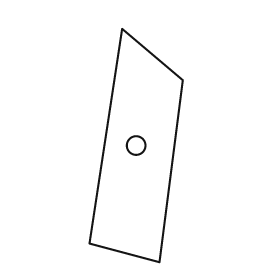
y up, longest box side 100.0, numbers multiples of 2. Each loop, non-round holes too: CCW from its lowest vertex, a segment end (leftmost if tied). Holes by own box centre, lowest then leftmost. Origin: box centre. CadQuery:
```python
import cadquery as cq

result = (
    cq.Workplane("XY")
    .moveTo(10.0, -50.0)
    .lineTo(20.0, 28.0)
    .lineTo(-6.0, 50.0)
    .lineTo(-20.0, -42.0)
    .close()
    .moveTo(0.0, 0.0)
    .circle(4.0)
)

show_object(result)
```